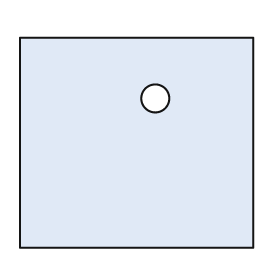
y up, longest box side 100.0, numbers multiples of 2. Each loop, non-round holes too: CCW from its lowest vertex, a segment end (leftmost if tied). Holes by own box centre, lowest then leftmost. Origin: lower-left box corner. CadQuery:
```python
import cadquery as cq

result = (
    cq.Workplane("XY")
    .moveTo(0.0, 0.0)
    .lineTo(100.0, 0.0)
    .lineTo(100.0, 90.0)
    .lineTo(0.0, 90.0)
    .close()
    .moveTo(58.0, 64.0)
    .circle(6.0)
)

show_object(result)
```